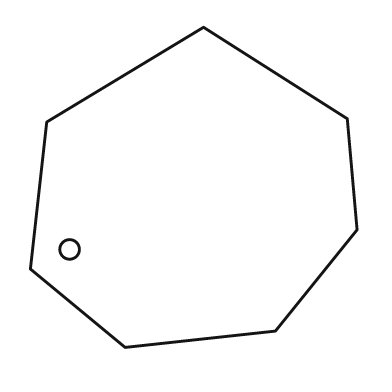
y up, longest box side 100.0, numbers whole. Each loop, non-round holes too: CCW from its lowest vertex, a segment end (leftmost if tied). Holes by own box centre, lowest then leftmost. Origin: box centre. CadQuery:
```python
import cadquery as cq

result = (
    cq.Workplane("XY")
    .moveTo(-21.0, -49.0)
    .lineTo(25.0, -44.0)
    .lineTo(50.0, -13.0)
    .lineTo(47.0, 21.0)
    .lineTo(3.0, 49.0)
    .lineTo(-45.0, 20.0)
    .lineTo(-50.0, -25.0)
    .close()
    .moveTo(-38.0, -19.0)
    .circle(3.0)
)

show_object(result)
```